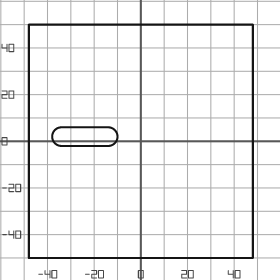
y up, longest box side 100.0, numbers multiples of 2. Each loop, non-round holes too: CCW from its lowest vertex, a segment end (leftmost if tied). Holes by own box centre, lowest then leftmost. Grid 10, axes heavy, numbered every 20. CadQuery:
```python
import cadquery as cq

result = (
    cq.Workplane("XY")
    .moveTo(-48.0, -50.0)
    .lineTo(48.0, -50.0)
    .lineTo(48.0, 50.0)
    .lineTo(-48.0, 50.0)
    .close()
    .moveTo(-34.0, -2.0)
    .lineTo(-14.0, -2.0)
    .threePointArc((-10.0, 2.0), (-14.0, 6.0))
    .lineTo(-34.0, 6.0)
    .threePointArc((-38.0, 2.0), (-34.0, -2.0))
    .close()
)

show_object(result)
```